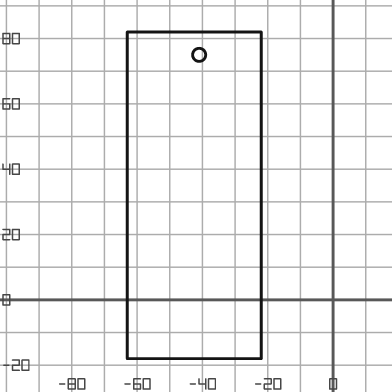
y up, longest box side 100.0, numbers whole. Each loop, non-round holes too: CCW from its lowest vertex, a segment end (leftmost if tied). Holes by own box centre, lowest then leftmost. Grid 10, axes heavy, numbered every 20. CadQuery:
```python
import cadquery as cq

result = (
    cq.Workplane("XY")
    .moveTo(-63.0, -18.0)
    .lineTo(-22.0, -18.0)
    .lineTo(-22.0, 82.0)
    .lineTo(-63.0, 82.0)
    .close()
    .moveTo(-41.0, 75.0)
    .circle(2.0)
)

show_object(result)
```